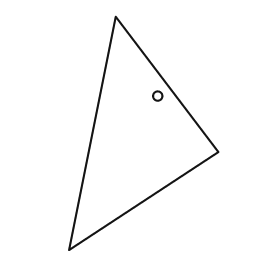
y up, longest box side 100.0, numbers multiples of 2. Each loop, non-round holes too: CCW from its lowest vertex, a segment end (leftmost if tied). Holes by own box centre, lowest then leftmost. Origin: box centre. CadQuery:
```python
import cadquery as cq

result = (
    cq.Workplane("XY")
    .moveTo(-32.0, -50.0)
    .lineTo(32.0, -8.0)
    .lineTo(-12.0, 50.0)
    .close()
    .moveTo(6.0, 16.0)
    .circle(2.0)
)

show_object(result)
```